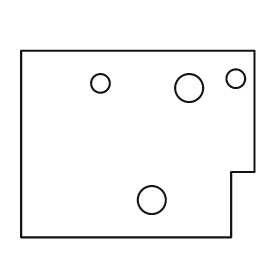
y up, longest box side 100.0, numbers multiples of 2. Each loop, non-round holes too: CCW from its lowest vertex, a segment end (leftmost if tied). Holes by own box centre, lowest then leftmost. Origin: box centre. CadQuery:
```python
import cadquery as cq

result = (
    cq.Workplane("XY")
    .moveTo(-50.0, -40.0)
    .lineTo(40.0, -40.0)
    .lineTo(40.0, -12.0)
    .lineTo(50.0, -12.0)
    .lineTo(50.0, 40.0)
    .lineTo(-50.0, 40.0)
    .close()
    .moveTo(6.0, -24.0)
    .circle(6.0)
    .moveTo(22.0, 24.0)
    .circle(6.0)
    .moveTo(-16.0, 26.0)
    .circle(4.0)
    .moveTo(42.0, 28.0)
    .circle(4.0)
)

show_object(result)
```